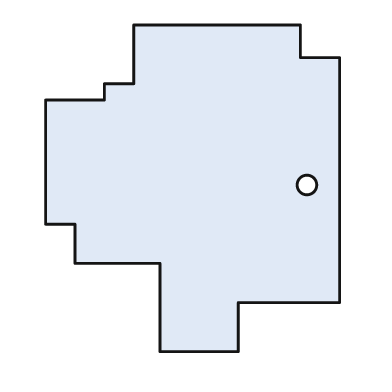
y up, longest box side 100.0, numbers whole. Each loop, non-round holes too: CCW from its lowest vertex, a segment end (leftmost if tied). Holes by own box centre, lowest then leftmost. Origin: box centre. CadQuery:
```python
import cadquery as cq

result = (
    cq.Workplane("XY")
    .moveTo(-10.0, -50.0)
    .lineTo(14.0, -50.0)
    .lineTo(14.0, -35.0)
    .lineTo(45.0, -35.0)
    .lineTo(45.0, 40.0)
    .lineTo(33.0, 40.0)
    .lineTo(33.0, 50.0)
    .lineTo(-18.0, 50.0)
    .lineTo(-18.0, 32.0)
    .lineTo(-27.0, 32.0)
    .lineTo(-27.0, 27.0)
    .lineTo(-45.0, 27.0)
    .lineTo(-45.0, -11.0)
    .lineTo(-36.0, -11.0)
    .lineTo(-36.0, -23.0)
    .lineTo(-10.0, -23.0)
    .close()
    .moveTo(35.0, 1.0)
    .circle(3.0)
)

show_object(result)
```